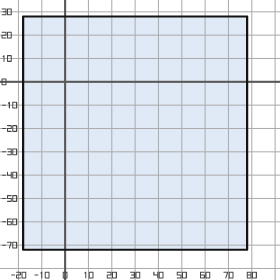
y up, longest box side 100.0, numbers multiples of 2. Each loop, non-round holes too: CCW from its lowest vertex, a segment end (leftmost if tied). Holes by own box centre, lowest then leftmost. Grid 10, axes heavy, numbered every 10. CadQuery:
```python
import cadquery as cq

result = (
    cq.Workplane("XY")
    .moveTo(-18.0, -72.0)
    .lineTo(78.0, -72.0)
    .lineTo(78.0, 28.0)
    .lineTo(-18.0, 28.0)
    .close()
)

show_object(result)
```